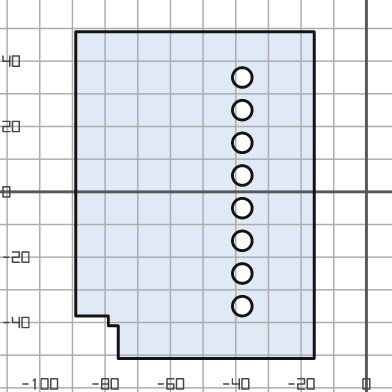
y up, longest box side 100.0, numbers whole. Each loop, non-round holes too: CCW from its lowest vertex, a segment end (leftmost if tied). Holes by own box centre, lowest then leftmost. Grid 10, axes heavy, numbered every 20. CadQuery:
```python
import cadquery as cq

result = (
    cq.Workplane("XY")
    .moveTo(-76.0, -51.0)
    .lineTo(-16.0, -51.0)
    .lineTo(-16.0, 49.0)
    .lineTo(-89.0, 49.0)
    .lineTo(-89.0, -38.0)
    .lineTo(-79.0, -38.0)
    .lineTo(-79.0, -41.0)
    .lineTo(-76.0, -41.0)
    .close()
    .moveTo(-38.0, -35.0)
    .circle(3.0)
    .moveTo(-38.0, -25.0)
    .circle(3.0)
    .moveTo(-38.0, -15.0)
    .circle(3.0)
    .moveTo(-38.0, -5.0)
    .circle(3.0)
    .moveTo(-38.0, 5.0)
    .circle(3.0)
    .moveTo(-38.0, 15.0)
    .circle(3.0)
    .moveTo(-38.0, 25.0)
    .circle(3.0)
    .moveTo(-38.0, 35.0)
    .circle(3.0)
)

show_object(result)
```